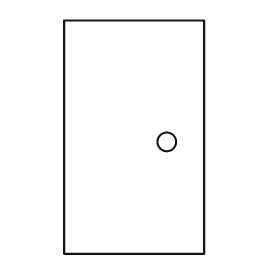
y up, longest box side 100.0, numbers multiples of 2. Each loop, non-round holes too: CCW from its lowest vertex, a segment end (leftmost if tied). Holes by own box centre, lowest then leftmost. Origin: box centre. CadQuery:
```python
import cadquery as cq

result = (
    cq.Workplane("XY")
    .moveTo(-30.0, -50.0)
    .lineTo(30.0, -50.0)
    .lineTo(30.0, 50.0)
    .lineTo(-30.0, 50.0)
    .close()
    .moveTo(14.0, -2.0)
    .circle(4.0)
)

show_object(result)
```